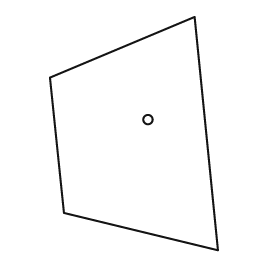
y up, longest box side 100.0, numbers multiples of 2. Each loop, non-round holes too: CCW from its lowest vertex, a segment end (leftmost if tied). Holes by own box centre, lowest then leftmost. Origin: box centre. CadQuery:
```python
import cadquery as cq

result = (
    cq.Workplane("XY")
    .moveTo(36.0, -50.0)
    .lineTo(26.0, 50.0)
    .lineTo(-36.0, 24.0)
    .lineTo(-30.0, -34.0)
    .close()
    .moveTo(6.0, 6.0)
    .circle(2.0)
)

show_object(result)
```